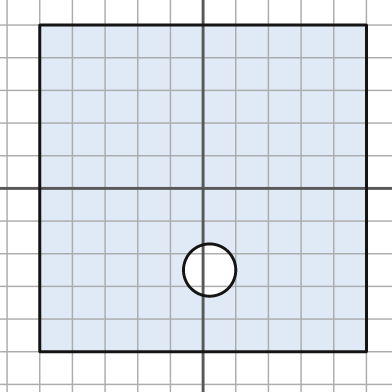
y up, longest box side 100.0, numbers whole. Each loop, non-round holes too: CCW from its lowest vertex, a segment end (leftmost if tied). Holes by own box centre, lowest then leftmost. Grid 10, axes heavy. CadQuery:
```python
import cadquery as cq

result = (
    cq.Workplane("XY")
    .moveTo(-50.0, -50.0)
    .lineTo(50.0, -50.0)
    .lineTo(50.0, 50.0)
    .lineTo(-50.0, 50.0)
    .close()
    .moveTo(2.0, -25.0)
    .circle(8.0)
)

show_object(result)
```